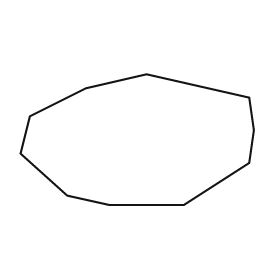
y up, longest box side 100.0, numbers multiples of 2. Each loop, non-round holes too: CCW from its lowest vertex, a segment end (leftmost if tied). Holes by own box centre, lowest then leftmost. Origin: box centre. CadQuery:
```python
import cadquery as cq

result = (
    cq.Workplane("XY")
    .moveTo(-12.0, -28.0)
    .lineTo(20.0, -28.0)
    .lineTo(48.0, -10.0)
    .lineTo(50.0, 4.0)
    .lineTo(48.0, 18.0)
    .lineTo(4.0, 28.0)
    .lineTo(-22.0, 22.0)
    .lineTo(-46.0, 10.0)
    .lineTo(-50.0, -6.0)
    .lineTo(-30.0, -24.0)
    .close()
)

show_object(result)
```